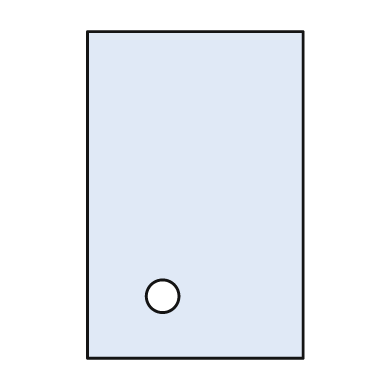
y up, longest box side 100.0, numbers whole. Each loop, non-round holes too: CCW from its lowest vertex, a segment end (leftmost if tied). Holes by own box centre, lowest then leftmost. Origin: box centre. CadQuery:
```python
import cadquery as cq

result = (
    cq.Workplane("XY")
    .moveTo(-33.0, -50.0)
    .lineTo(33.0, -50.0)
    .lineTo(33.0, 50.0)
    .lineTo(-33.0, 50.0)
    .close()
    .moveTo(-10.0, -31.0)
    .circle(5.0)
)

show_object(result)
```